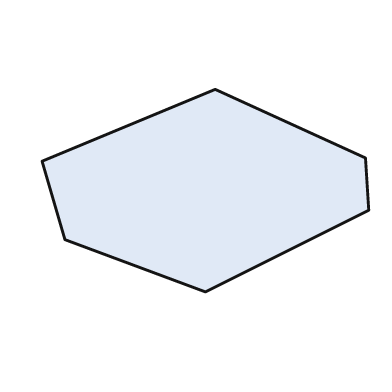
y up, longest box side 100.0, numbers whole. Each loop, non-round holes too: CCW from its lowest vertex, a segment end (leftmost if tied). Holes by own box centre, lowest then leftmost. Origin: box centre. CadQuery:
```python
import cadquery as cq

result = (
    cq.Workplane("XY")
    .moveTo(0.0, -31.0)
    .lineTo(50.0, -6.0)
    .lineTo(49.0, 10.0)
    .lineTo(3.0, 31.0)
    .lineTo(-50.0, 9.0)
    .lineTo(-43.0, -15.0)
    .close()
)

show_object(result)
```